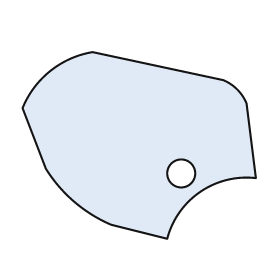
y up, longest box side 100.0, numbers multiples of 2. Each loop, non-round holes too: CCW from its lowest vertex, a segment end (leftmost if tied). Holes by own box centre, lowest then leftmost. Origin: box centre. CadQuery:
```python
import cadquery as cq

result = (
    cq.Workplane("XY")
    .moveTo(12.0, -40.0)
    .threePointArc((26.0, -20.0), (50.0, -14.0))
    .lineTo(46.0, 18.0)
    .threePointArc((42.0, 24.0), (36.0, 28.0))
    .lineTo(-20.0, 40.0)
    .threePointArc((-38.0, 32.0), (-50.0, 16.0))
    .lineTo(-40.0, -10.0)
    .threePointArc((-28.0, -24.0), (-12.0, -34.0))
    .close()
    .moveTo(18.0, -12.0)
    .circle(6.0)
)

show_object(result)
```